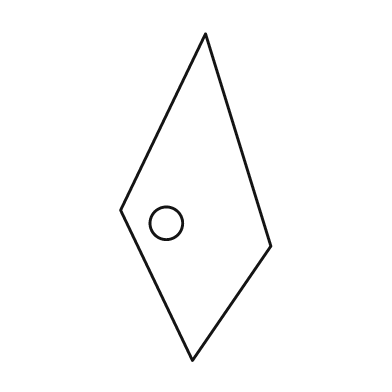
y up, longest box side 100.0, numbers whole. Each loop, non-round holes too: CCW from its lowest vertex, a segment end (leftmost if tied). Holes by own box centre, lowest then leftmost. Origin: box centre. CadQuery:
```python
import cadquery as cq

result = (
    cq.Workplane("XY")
    .moveTo(-1.0, -50.0)
    .lineTo(23.0, -15.0)
    .lineTo(3.0, 50.0)
    .lineTo(-23.0, -4.0)
    .close()
    .moveTo(-9.0, -8.0)
    .circle(5.0)
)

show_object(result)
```